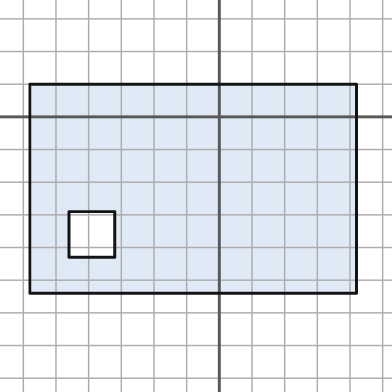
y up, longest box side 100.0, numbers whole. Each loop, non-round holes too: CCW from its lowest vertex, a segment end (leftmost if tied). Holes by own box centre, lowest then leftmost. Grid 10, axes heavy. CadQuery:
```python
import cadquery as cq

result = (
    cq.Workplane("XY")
    .moveTo(-58.0, -54.0)
    .lineTo(42.0, -54.0)
    .lineTo(42.0, 10.0)
    .lineTo(-58.0, 10.0)
    .close()
    .moveTo(-46.0, -43.0)
    .lineTo(-32.0, -43.0)
    .lineTo(-32.0, -29.0)
    .lineTo(-46.0, -29.0)
    .close()
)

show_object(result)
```